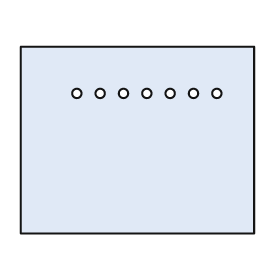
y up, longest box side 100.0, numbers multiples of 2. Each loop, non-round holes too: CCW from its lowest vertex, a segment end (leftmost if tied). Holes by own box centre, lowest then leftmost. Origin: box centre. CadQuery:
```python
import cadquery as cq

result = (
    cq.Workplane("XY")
    .moveTo(-50.0, -40.0)
    .lineTo(50.0, -40.0)
    .lineTo(50.0, 40.0)
    .lineTo(-50.0, 40.0)
    .close()
    .moveTo(-26.0, 20.0)
    .circle(2.0)
    .moveTo(-16.0, 20.0)
    .circle(2.0)
    .moveTo(-6.0, 20.0)
    .circle(2.0)
    .moveTo(4.0, 20.0)
    .circle(2.0)
    .moveTo(14.0, 20.0)
    .circle(2.0)
    .moveTo(24.0, 20.0)
    .circle(2.0)
    .moveTo(34.0, 20.0)
    .circle(2.0)
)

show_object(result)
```